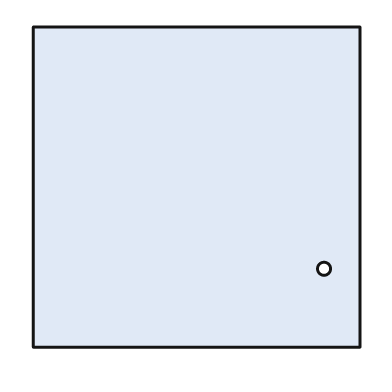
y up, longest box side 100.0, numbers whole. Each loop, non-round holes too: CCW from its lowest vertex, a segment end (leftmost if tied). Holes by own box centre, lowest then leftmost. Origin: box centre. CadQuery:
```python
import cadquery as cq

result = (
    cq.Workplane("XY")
    .moveTo(-50.0, -49.0)
    .lineTo(50.0, -49.0)
    .lineTo(50.0, 49.0)
    .lineTo(-50.0, 49.0)
    .close()
    .moveTo(39.0, -25.0)
    .circle(2.0)
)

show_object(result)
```